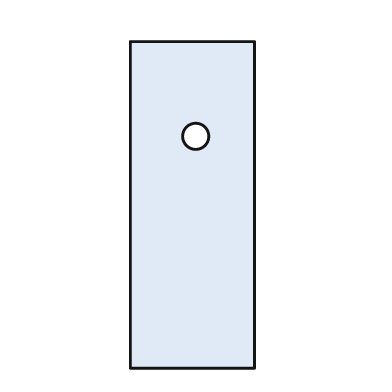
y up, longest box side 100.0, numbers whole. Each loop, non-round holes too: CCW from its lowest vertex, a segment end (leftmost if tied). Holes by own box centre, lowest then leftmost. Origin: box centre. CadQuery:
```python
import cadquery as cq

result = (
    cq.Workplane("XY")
    .moveTo(-19.0, -50.0)
    .lineTo(19.0, -50.0)
    .lineTo(19.0, 50.0)
    .lineTo(-19.0, 50.0)
    .close()
    .moveTo(1.0, 21.0)
    .circle(4.0)
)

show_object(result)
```